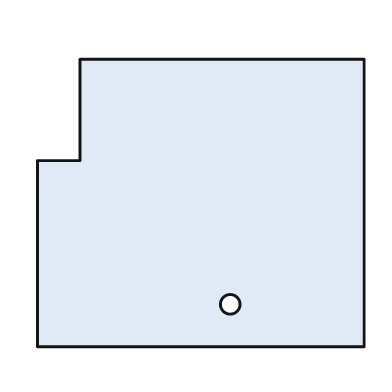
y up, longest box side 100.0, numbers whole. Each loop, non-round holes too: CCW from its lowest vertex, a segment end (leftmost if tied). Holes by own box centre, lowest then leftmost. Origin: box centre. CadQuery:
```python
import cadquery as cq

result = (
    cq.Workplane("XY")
    .moveTo(-50.0, -44.0)
    .lineTo(50.0, -44.0)
    .lineTo(50.0, 44.0)
    .lineTo(-37.0, 44.0)
    .lineTo(-37.0, 13.0)
    .lineTo(-50.0, 13.0)
    .close()
    .moveTo(9.0, -31.0)
    .circle(3.0)
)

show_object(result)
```